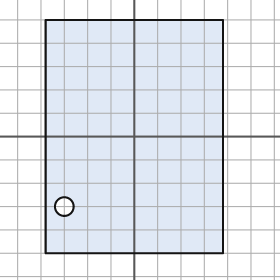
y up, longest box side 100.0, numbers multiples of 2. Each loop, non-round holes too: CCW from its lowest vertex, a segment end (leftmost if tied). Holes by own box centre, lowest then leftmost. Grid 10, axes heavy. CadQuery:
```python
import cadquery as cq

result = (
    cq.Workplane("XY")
    .moveTo(-38.0, -50.0)
    .lineTo(38.0, -50.0)
    .lineTo(38.0, 50.0)
    .lineTo(-38.0, 50.0)
    .close()
    .moveTo(-30.0, -30.0)
    .circle(4.0)
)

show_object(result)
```